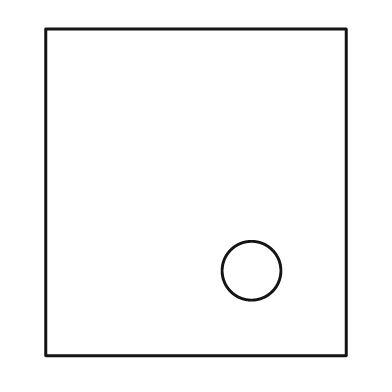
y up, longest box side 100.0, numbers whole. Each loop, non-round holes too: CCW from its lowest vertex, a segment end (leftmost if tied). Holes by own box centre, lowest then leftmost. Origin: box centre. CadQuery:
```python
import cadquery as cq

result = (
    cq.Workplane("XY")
    .moveTo(-46.0, -50.0)
    .lineTo(46.0, -50.0)
    .lineTo(46.0, 50.0)
    .lineTo(-46.0, 50.0)
    .close()
    .moveTo(17.0, -24.0)
    .circle(9.0)
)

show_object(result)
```